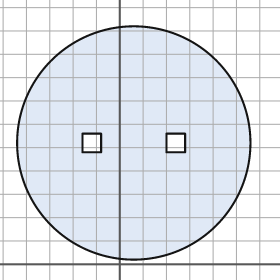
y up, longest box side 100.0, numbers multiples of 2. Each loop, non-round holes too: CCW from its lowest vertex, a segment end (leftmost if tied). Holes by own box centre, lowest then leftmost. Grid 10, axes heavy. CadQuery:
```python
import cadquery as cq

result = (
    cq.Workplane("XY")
    .moveTo(6.0, 52.0)
    .circle(50.0)
    .moveTo(-16.0, 48.0)
    .lineTo(-8.0, 48.0)
    .lineTo(-8.0, 56.0)
    .lineTo(-16.0, 56.0)
    .close()
    .moveTo(20.0, 48.0)
    .lineTo(28.0, 48.0)
    .lineTo(28.0, 56.0)
    .lineTo(20.0, 56.0)
    .close()
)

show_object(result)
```